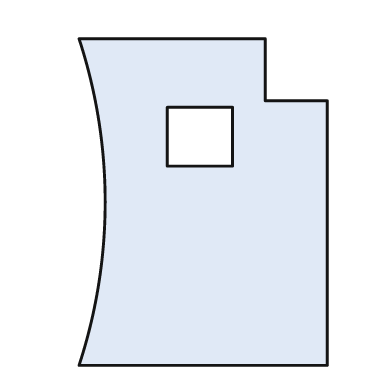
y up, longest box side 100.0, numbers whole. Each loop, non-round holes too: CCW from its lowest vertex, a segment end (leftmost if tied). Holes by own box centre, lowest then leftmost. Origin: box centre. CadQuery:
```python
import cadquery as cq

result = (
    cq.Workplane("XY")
    .moveTo(-38.0, -50.0)
    .lineTo(38.0, -50.0)
    .lineTo(38.0, 31.0)
    .lineTo(19.0, 31.0)
    .lineTo(19.0, 50.0)
    .lineTo(-38.0, 50.0)
    .threePointArc((-30.0, 0.0), (-38.0, -50.0))
    .close()
    .moveTo(-11.0, 11.0)
    .lineTo(9.0, 11.0)
    .lineTo(9.0, 29.0)
    .lineTo(-11.0, 29.0)
    .close()
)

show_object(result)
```